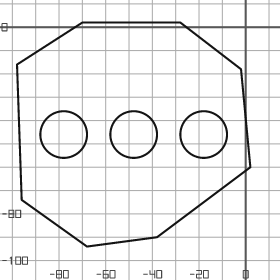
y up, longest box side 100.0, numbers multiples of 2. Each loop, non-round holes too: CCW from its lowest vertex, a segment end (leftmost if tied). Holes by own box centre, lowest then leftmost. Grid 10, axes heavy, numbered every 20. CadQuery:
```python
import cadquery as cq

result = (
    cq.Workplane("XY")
    .moveTo(-68.0, -94.0)
    .lineTo(-38.0, -90.0)
    .lineTo(2.0, -60.0)
    .lineTo(-2.0, -18.0)
    .lineTo(-28.0, 2.0)
    .lineTo(-70.0, 2.0)
    .lineTo(-98.0, -16.0)
    .lineTo(-96.0, -74.0)
    .close()
    .moveTo(-78.0, -46.0)
    .circle(10.0)
    .moveTo(-48.0, -46.0)
    .circle(10.0)
    .moveTo(-18.0, -46.0)
    .circle(10.0)
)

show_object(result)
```